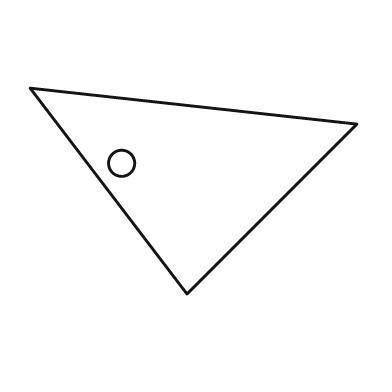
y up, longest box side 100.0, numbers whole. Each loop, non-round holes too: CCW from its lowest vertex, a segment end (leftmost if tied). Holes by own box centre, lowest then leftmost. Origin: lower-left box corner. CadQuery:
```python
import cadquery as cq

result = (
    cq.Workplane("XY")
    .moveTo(48.0, 0.0)
    .lineTo(100.0, 52.0)
    .lineTo(0.0, 63.0)
    .close()
    .moveTo(28.0, 40.0)
    .circle(4.0)
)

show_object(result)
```